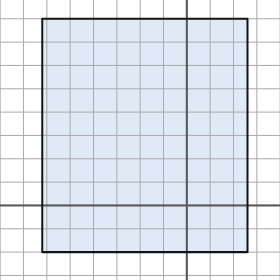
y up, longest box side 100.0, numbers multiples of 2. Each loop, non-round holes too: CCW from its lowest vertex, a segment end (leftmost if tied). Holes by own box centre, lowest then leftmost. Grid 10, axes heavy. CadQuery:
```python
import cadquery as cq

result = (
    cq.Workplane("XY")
    .moveTo(-62.0, -20.0)
    .lineTo(26.0, -20.0)
    .lineTo(26.0, 80.0)
    .lineTo(-62.0, 80.0)
    .close()
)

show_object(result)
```